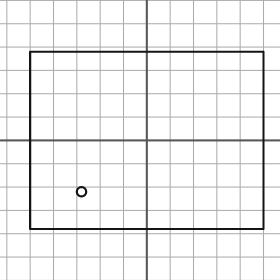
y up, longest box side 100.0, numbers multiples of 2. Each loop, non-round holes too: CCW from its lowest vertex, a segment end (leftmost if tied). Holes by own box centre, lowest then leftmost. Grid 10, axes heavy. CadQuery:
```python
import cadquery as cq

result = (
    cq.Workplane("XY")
    .moveTo(-50.0, -38.0)
    .lineTo(50.0, -38.0)
    .lineTo(50.0, 38.0)
    .lineTo(-50.0, 38.0)
    .close()
    .moveTo(-28.0, -22.0)
    .circle(2.0)
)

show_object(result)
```